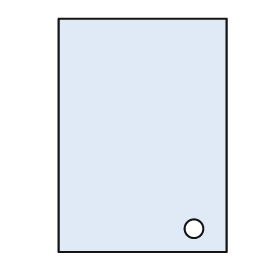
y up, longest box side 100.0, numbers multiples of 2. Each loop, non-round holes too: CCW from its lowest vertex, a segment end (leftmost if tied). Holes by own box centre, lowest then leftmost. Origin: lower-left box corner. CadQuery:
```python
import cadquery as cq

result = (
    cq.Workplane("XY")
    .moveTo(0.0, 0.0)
    .lineTo(72.0, 0.0)
    .lineTo(72.0, 100.0)
    .lineTo(0.0, 100.0)
    .close()
    .moveTo(58.0, 10.0)
    .circle(4.0)
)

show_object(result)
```